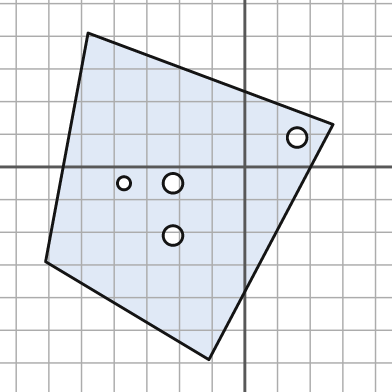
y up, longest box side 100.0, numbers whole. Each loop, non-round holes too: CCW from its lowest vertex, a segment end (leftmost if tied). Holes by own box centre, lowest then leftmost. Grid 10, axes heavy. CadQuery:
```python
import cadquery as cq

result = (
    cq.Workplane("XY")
    .moveTo(-11.0, -59.0)
    .lineTo(27.0, 13.0)
    .lineTo(-48.0, 41.0)
    .lineTo(-61.0, -29.0)
    .close()
    .moveTo(-22.0, -21.0)
    .circle(3.0)
    .moveTo(-37.0, -5.0)
    .circle(2.0)
    .moveTo(-22.0, -5.0)
    .circle(3.0)
    .moveTo(16.0, 9.0)
    .circle(3.0)
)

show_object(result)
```